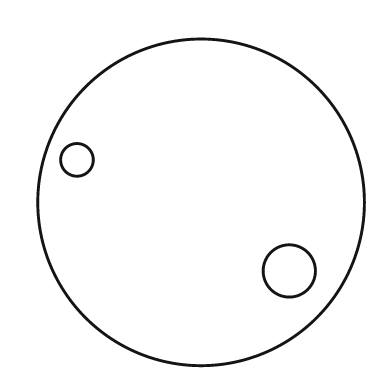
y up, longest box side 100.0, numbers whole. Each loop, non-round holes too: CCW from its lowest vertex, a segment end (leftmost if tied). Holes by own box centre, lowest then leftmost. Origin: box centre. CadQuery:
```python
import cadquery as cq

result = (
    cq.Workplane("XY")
    .moveTo(0.0, 0.0)
    .circle(50.0)
    .moveTo(27.0, -21.0)
    .circle(8.0)
    .moveTo(-38.0, 13.0)
    .circle(5.0)
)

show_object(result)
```